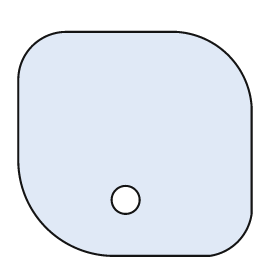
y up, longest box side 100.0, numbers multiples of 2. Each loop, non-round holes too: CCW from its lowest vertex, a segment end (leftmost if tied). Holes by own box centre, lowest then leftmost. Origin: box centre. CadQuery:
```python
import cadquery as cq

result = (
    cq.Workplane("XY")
    .moveTo(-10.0, -48.0)
    .lineTo(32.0, -48.0)
    .threePointArc((44.0, -42.0), (50.0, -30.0))
    .lineTo(50.0, 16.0)
    .threePointArc((40.0, 38.0), (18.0, 48.0))
    .lineTo(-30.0, 48.0)
    .threePointArc((-44.0, 42.0), (-50.0, 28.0))
    .lineTo(-50.0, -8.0)
    .threePointArc((-38.0, -36.0), (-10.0, -48.0))
    .close()
    .moveTo(-4.0, -24.0)
    .circle(6.0)
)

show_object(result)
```